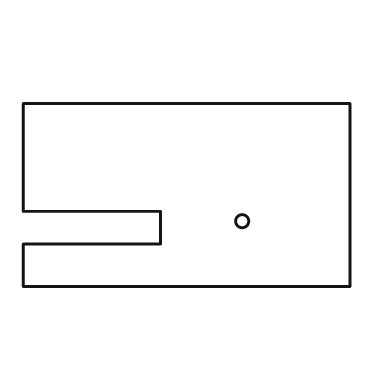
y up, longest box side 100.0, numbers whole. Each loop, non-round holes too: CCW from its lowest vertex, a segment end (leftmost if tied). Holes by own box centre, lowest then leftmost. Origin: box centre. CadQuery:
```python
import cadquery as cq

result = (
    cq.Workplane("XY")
    .moveTo(-50.0, -28.0)
    .lineTo(50.0, -28.0)
    .lineTo(50.0, 28.0)
    .lineTo(-50.0, 28.0)
    .lineTo(-50.0, -5.0)
    .lineTo(-8.0, -5.0)
    .lineTo(-8.0, -15.0)
    .lineTo(-50.0, -15.0)
    .close()
    .moveTo(17.0, -8.0)
    .circle(2.0)
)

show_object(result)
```